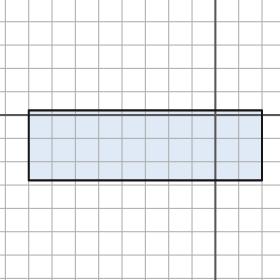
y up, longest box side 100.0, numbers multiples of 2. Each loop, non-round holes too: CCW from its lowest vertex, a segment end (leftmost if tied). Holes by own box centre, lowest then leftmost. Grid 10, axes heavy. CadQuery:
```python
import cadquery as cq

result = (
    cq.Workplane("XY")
    .moveTo(-80.0, -28.0)
    .lineTo(20.0, -28.0)
    .lineTo(20.0, 2.0)
    .lineTo(-80.0, 2.0)
    .close()
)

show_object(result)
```